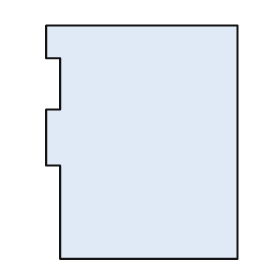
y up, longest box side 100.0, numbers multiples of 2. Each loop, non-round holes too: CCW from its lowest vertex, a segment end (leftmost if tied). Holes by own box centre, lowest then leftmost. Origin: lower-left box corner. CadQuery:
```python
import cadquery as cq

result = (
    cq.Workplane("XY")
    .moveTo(6.0, 0.0)
    .lineTo(82.0, 0.0)
    .lineTo(82.0, 100.0)
    .lineTo(0.0, 100.0)
    .lineTo(0.0, 86.0)
    .lineTo(6.0, 86.0)
    .lineTo(6.0, 64.0)
    .lineTo(0.0, 64.0)
    .lineTo(0.0, 40.0)
    .lineTo(6.0, 40.0)
    .close()
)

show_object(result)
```